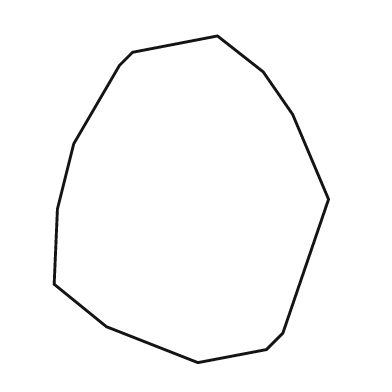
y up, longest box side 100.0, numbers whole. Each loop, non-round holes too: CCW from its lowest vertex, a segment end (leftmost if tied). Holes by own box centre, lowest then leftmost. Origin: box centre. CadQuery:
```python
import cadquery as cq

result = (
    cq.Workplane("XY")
    .moveTo(2.0, -50.0)
    .lineTo(23.0, -46.0)
    .lineTo(28.0, -41.0)
    .lineTo(42.0, 0.0)
    .lineTo(31.0, 26.0)
    .lineTo(22.0, 39.0)
    .lineTo(8.0, 50.0)
    .lineTo(-18.0, 45.0)
    .lineTo(-22.0, 41.0)
    .lineTo(-36.0, 17.0)
    .lineTo(-41.0, -3.0)
    .lineTo(-42.0, -26.0)
    .lineTo(-26.0, -39.0)
    .close()
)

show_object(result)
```